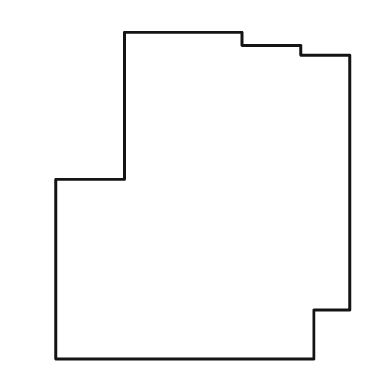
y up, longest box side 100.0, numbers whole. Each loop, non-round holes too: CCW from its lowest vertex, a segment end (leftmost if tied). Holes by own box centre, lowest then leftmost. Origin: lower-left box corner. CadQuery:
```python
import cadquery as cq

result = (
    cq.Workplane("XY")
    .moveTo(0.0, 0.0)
    .lineTo(79.0, 0.0)
    .lineTo(79.0, 15.0)
    .lineTo(90.0, 15.0)
    .lineTo(90.0, 93.0)
    .lineTo(75.0, 93.0)
    .lineTo(75.0, 96.0)
    .lineTo(57.0, 96.0)
    .lineTo(57.0, 100.0)
    .lineTo(21.0, 100.0)
    .lineTo(21.0, 55.0)
    .lineTo(0.0, 55.0)
    .close()
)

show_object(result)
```